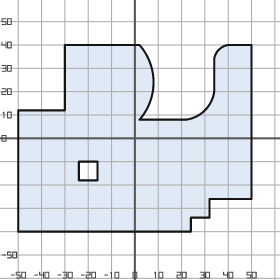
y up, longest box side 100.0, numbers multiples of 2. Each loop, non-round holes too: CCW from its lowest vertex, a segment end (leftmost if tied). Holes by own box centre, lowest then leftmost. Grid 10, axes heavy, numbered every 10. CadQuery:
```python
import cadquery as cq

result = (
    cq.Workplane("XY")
    .moveTo(-50.0, -40.0)
    .lineTo(24.0, -40.0)
    .lineTo(24.0, -34.0)
    .lineTo(32.0, -34.0)
    .lineTo(32.0, -26.0)
    .lineTo(50.0, -26.0)
    .lineTo(50.0, 40.0)
    .lineTo(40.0, 40.0)
    .threePointArc((36.0, 38.0), (34.0, 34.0))
    .lineTo(34.0, 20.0)
    .threePointArc((30.0, 12.0), (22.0, 8.0))
    .lineTo(2.0, 8.0)
    .threePointArc((8.0, 24.0), (2.0, 40.0))
    .lineTo(-30.0, 40.0)
    .lineTo(-30.0, 12.0)
    .lineTo(-50.0, 12.0)
    .close()
    .moveTo(-24.0, -18.0)
    .lineTo(-16.0, -18.0)
    .lineTo(-16.0, -10.0)
    .lineTo(-24.0, -10.0)
    .close()
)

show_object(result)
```